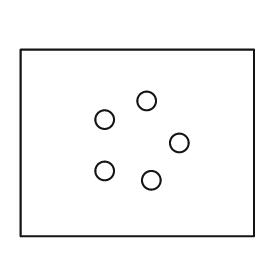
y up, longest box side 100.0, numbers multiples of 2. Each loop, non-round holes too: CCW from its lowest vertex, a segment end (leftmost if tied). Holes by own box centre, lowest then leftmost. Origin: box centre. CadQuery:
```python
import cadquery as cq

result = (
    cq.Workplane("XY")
    .moveTo(-50.0, -40.0)
    .lineTo(50.0, -40.0)
    .lineTo(50.0, 40.0)
    .lineTo(-50.0, 40.0)
    .close()
    .moveTo(6.0, -16.0)
    .circle(4.0)
    .moveTo(-14.0, -12.0)
    .circle(4.0)
    .moveTo(18.0, 0.0)
    .circle(4.0)
    .moveTo(-14.0, 10.0)
    .circle(4.0)
    .moveTo(4.0, 18.0)
    .circle(4.0)
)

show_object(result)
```